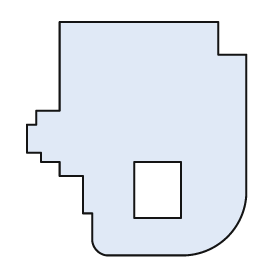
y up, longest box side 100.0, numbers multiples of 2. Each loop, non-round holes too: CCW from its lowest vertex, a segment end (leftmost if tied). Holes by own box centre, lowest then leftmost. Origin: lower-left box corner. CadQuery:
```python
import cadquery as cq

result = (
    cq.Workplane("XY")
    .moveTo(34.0, 0.0)
    .lineTo(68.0, 0.0)
    .threePointArc((86.0, 8.0), (94.0, 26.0))
    .lineTo(94.0, 86.0)
    .lineTo(82.0, 86.0)
    .lineTo(82.0, 100.0)
    .lineTo(14.0, 100.0)
    .lineTo(14.0, 62.0)
    .lineTo(4.0, 62.0)
    .lineTo(4.0, 56.0)
    .lineTo(0.0, 56.0)
    .lineTo(0.0, 44.0)
    .lineTo(6.0, 44.0)
    .lineTo(6.0, 40.0)
    .lineTo(14.0, 40.0)
    .lineTo(14.0, 34.0)
    .lineTo(24.0, 34.0)
    .lineTo(24.0, 18.0)
    .lineTo(28.0, 18.0)
    .lineTo(28.0, 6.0)
    .threePointArc((30.0, 2.0), (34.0, 0.0))
    .close()
    .moveTo(46.0, 16.0)
    .lineTo(66.0, 16.0)
    .lineTo(66.0, 40.0)
    .lineTo(46.0, 40.0)
    .close()
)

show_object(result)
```